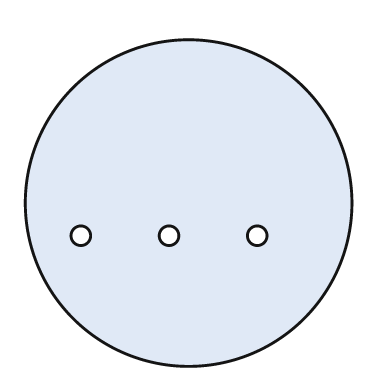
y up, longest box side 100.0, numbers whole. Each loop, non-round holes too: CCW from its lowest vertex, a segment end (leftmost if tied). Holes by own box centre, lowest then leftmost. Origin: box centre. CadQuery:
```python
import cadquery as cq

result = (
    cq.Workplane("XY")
    .moveTo(0.0, 0.0)
    .circle(50.0)
    .moveTo(-33.0, -10.0)
    .circle(3.0)
    .moveTo(-6.0, -10.0)
    .circle(3.0)
    .moveTo(21.0, -10.0)
    .circle(3.0)
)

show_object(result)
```